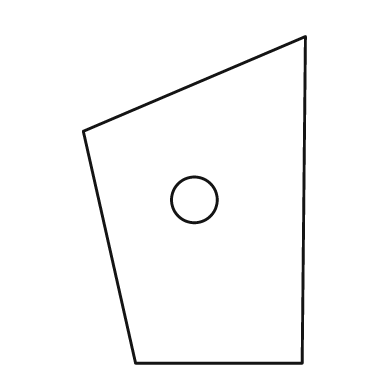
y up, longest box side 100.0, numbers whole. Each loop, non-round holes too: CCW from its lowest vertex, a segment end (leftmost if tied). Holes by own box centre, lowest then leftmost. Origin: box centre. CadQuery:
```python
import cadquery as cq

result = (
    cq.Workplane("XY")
    .moveTo(-18.0, -50.0)
    .lineTo(33.0, -50.0)
    .lineTo(34.0, 50.0)
    .lineTo(-34.0, 21.0)
    .close()
    .moveTo(0.0, 0.0)
    .circle(7.0)
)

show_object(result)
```